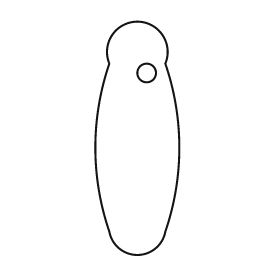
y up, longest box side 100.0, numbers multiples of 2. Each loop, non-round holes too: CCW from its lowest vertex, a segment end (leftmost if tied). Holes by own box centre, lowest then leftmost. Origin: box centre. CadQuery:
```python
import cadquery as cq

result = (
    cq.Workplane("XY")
    .moveTo(-12.0, -40.0)
    .threePointArc((0.0, -50.0), (12.0, -40.0))
    .threePointArc((18.0, -4.0), (12.0, 32.0))
    .threePointArc((0.0, 50.0), (-12.0, 32.0))
    .threePointArc((-18.0, -4.0), (-12.0, -40.0))
    .close()
    .moveTo(4.0, 28.0)
    .circle(4.0)
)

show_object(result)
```